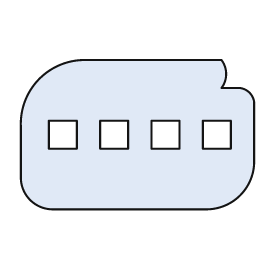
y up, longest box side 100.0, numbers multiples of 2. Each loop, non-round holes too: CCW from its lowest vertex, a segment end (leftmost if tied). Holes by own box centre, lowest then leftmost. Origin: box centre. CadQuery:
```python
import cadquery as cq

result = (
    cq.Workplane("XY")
    .moveTo(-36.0, -32.0)
    .lineTo(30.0, -32.0)
    .threePointArc((44.0, -26.0), (50.0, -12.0))
    .lineTo(50.0, 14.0)
    .threePointArc((48.0, 18.0), (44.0, 20.0))
    .lineTo(36.0, 20.0)
    .threePointArc((38.0, 26.0), (36.0, 32.0))
    .lineTo(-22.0, 32.0)
    .threePointArc((-42.0, 24.0), (-50.0, 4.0))
    .lineTo(-50.0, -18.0)
    .threePointArc((-46.0, -28.0), (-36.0, -32.0))
    .close()
    .moveTo(-38.0, -6.0)
    .lineTo(-26.0, -6.0)
    .lineTo(-26.0, 6.0)
    .lineTo(-38.0, 6.0)
    .close()
    .moveTo(-16.0, -6.0)
    .lineTo(-4.0, -6.0)
    .lineTo(-4.0, 6.0)
    .lineTo(-16.0, 6.0)
    .close()
    .moveTo(6.0, -6.0)
    .lineTo(18.0, -6.0)
    .lineTo(18.0, 6.0)
    .lineTo(6.0, 6.0)
    .close()
    .moveTo(28.0, -6.0)
    .lineTo(40.0, -6.0)
    .lineTo(40.0, 6.0)
    .lineTo(28.0, 6.0)
    .close()
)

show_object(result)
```